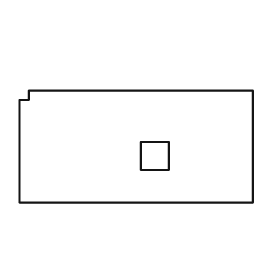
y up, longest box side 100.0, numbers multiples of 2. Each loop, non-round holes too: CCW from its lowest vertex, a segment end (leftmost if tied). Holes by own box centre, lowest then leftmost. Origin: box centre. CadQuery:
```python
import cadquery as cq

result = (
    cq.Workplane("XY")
    .moveTo(-50.0, -24.0)
    .lineTo(50.0, -24.0)
    .lineTo(50.0, 24.0)
    .lineTo(-46.0, 24.0)
    .lineTo(-46.0, 20.0)
    .lineTo(-50.0, 20.0)
    .close()
    .moveTo(2.0, -10.0)
    .lineTo(14.0, -10.0)
    .lineTo(14.0, 2.0)
    .lineTo(2.0, 2.0)
    .close()
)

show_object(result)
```